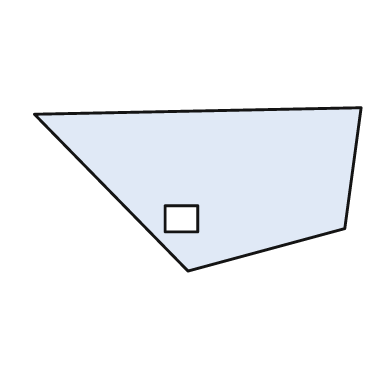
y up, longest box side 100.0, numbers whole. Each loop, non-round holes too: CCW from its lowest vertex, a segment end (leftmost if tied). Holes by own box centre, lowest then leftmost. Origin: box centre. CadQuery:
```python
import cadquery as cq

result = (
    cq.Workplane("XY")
    .moveTo(-3.0, -25.0)
    .lineTo(45.0, -12.0)
    .lineTo(50.0, 25.0)
    .lineTo(-50.0, 23.0)
    .close()
    .moveTo(-10.0, -13.0)
    .lineTo(0.0, -13.0)
    .lineTo(0.0, -5.0)
    .lineTo(-10.0, -5.0)
    .close()
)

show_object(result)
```